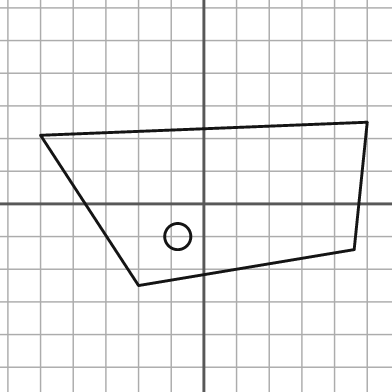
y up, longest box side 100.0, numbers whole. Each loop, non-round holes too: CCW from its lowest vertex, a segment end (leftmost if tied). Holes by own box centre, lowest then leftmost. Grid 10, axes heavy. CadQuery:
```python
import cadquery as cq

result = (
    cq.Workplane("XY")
    .moveTo(-20.0, -25.0)
    .lineTo(46.0, -14.0)
    .lineTo(50.0, 25.0)
    .lineTo(-50.0, 21.0)
    .close()
    .moveTo(-8.0, -10.0)
    .circle(4.0)
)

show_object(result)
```